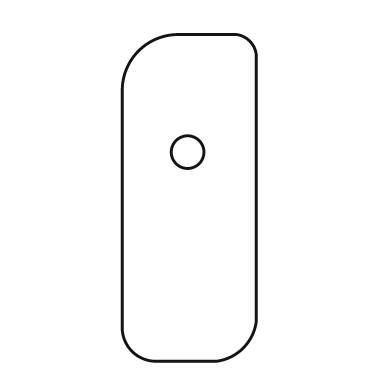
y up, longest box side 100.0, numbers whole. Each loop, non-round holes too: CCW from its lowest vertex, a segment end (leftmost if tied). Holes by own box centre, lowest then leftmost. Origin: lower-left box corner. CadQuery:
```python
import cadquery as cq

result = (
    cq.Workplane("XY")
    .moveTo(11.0, 0.0)
    .lineTo(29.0, 0.0)
    .threePointArc((37.0, 4.0), (41.0, 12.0))
    .lineTo(41.0, 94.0)
    .threePointArc((39.0, 98.0), (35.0, 100.0))
    .lineTo(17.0, 100.0)
    .threePointArc((5.0, 95.0), (0.0, 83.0))
    .lineTo(0.0, 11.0)
    .threePointArc((3.0, 3.0), (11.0, 0.0))
    .close()
    .moveTo(20.0, 64.0)
    .circle(5.0)
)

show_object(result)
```